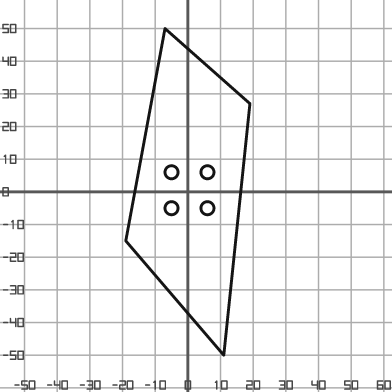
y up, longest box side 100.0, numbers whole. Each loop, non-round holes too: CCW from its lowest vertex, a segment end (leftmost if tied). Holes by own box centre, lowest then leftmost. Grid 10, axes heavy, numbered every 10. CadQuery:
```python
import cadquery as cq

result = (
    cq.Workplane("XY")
    .moveTo(11.0, -50.0)
    .lineTo(19.0, 27.0)
    .lineTo(-7.0, 50.0)
    .lineTo(-19.0, -15.0)
    .close()
    .moveTo(-5.0, -5.0)
    .circle(2.0)
    .moveTo(6.0, -5.0)
    .circle(2.0)
    .moveTo(-5.0, 6.0)
    .circle(2.0)
    .moveTo(6.0, 6.0)
    .circle(2.0)
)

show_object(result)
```